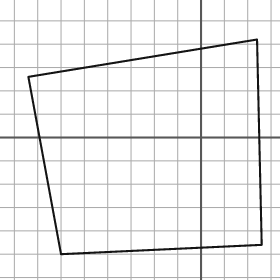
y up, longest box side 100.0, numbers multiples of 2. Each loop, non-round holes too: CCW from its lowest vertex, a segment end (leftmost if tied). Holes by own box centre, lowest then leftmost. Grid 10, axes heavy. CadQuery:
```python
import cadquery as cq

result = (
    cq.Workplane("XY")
    .moveTo(-60.0, -50.0)
    .lineTo(26.0, -46.0)
    .lineTo(24.0, 42.0)
    .lineTo(-74.0, 26.0)
    .close()
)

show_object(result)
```